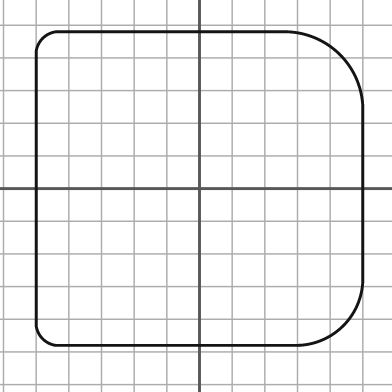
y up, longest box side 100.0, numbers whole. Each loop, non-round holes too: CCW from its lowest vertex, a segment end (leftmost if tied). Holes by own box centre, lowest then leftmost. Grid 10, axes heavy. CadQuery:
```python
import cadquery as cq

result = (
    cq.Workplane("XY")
    .moveTo(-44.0, -48.0)
    .lineTo(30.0, -48.0)
    .threePointArc((44.0, -42.0), (50.0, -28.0))
    .lineTo(50.0, 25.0)
    .threePointArc((43.0, 41.0), (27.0, 48.0))
    .lineTo(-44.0, 48.0)
    .threePointArc((-48.0, 46.0), (-50.0, 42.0))
    .lineTo(-50.0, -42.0)
    .threePointArc((-48.0, -46.0), (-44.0, -48.0))
    .close()
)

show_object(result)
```